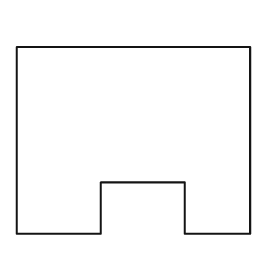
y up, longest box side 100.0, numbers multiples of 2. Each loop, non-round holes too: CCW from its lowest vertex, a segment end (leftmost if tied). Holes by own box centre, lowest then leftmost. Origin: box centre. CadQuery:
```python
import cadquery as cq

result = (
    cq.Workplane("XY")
    .moveTo(-50.0, -40.0)
    .lineTo(-14.0, -40.0)
    .lineTo(-14.0, -18.0)
    .lineTo(22.0, -18.0)
    .lineTo(22.0, -40.0)
    .lineTo(50.0, -40.0)
    .lineTo(50.0, 40.0)
    .lineTo(-50.0, 40.0)
    .close()
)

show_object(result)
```